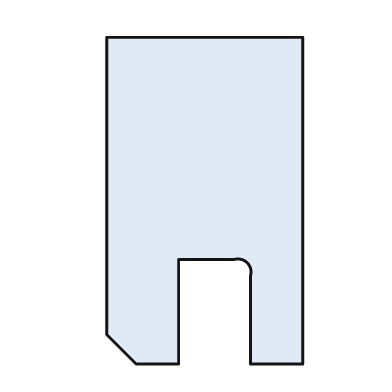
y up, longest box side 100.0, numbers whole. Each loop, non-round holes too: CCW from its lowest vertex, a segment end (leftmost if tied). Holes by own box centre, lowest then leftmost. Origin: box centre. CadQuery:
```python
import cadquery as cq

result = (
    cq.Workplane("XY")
    .moveTo(-21.0, -50.0)
    .lineTo(-8.0, -50.0)
    .lineTo(-8.0, -18.0)
    .lineTo(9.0, -18.0)
    .threePointArc((13.0, -19.0), (14.0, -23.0))
    .lineTo(14.0, -50.0)
    .lineTo(30.0, -50.0)
    .lineTo(30.0, 50.0)
    .lineTo(-30.0, 50.0)
    .lineTo(-30.0, -41.0)
    .close()
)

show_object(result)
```